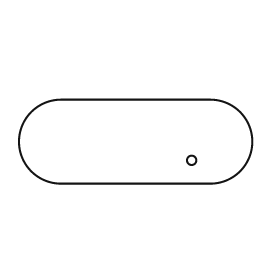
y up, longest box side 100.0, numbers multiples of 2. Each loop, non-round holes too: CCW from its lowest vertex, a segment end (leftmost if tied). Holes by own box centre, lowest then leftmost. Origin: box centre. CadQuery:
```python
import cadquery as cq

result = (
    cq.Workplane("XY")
    .moveTo(-32.0, -18.0)
    .lineTo(32.0, -18.0)
    .threePointArc((50.0, 0.0), (32.0, 18.0))
    .lineTo(-32.0, 18.0)
    .threePointArc((-50.0, 0.0), (-32.0, -18.0))
    .close()
    .moveTo(24.0, -8.0)
    .circle(2.0)
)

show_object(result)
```